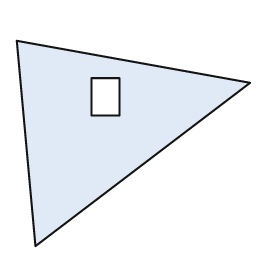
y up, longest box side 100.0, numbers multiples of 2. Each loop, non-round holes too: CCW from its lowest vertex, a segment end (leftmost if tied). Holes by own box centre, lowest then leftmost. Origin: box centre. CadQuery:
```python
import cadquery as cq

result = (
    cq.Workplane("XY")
    .moveTo(-42.0, -44.0)
    .lineTo(50.0, 26.0)
    .lineTo(-50.0, 44.0)
    .close()
    .moveTo(-18.0, 12.0)
    .lineTo(-6.0, 12.0)
    .lineTo(-6.0, 28.0)
    .lineTo(-18.0, 28.0)
    .close()
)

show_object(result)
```